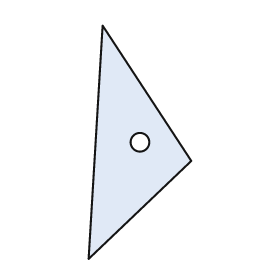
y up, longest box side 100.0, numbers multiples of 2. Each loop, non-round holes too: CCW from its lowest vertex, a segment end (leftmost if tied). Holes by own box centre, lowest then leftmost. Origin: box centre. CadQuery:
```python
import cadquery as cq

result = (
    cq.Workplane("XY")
    .moveTo(-22.0, -50.0)
    .lineTo(22.0, -8.0)
    .lineTo(-16.0, 50.0)
    .close()
    .moveTo(0.0, 0.0)
    .circle(4.0)
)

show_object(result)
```